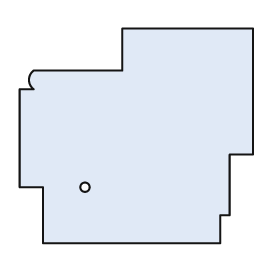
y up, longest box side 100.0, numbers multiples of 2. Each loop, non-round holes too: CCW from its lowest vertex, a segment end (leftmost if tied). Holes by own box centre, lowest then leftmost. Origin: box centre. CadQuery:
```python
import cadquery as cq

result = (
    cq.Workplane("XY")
    .moveTo(-40.0, -46.0)
    .lineTo(36.0, -46.0)
    .lineTo(36.0, -34.0)
    .lineTo(40.0, -34.0)
    .lineTo(40.0, -8.0)
    .lineTo(50.0, -8.0)
    .lineTo(50.0, 46.0)
    .lineTo(-6.0, 46.0)
    .lineTo(-6.0, 28.0)
    .lineTo(-44.0, 28.0)
    .threePointArc((-46.0, 24.0), (-44.0, 20.0))
    .lineTo(-50.0, 20.0)
    .lineTo(-50.0, -22.0)
    .lineTo(-40.0, -22.0)
    .close()
    .moveTo(-22.0, -22.0)
    .circle(2.0)
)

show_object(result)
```